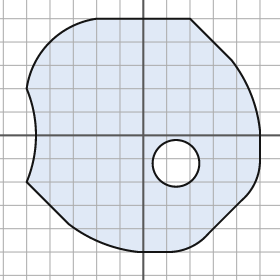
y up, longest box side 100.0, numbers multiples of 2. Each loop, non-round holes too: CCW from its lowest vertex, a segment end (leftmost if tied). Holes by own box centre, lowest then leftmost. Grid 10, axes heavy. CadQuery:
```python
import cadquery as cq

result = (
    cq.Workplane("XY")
    .moveTo(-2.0, -50.0)
    .lineTo(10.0, -50.0)
    .threePointArc((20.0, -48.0), (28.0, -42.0))
    .lineTo(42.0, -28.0)
    .threePointArc((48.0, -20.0), (50.0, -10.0))
    .lineTo(50.0, 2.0)
    .threePointArc((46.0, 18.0), (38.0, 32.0))
    .lineTo(20.0, 50.0)
    .lineTo(-20.0, 50.0)
    .threePointArc((-40.0, 40.0), (-50.0, 20.0))
    .threePointArc((-46.0, 0.0), (-50.0, -20.0))
    .lineTo(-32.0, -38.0)
    .threePointArc((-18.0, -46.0), (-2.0, -50.0))
    .close()
    .moveTo(14.0, -12.0)
    .circle(10.0)
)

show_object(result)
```